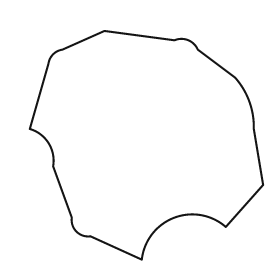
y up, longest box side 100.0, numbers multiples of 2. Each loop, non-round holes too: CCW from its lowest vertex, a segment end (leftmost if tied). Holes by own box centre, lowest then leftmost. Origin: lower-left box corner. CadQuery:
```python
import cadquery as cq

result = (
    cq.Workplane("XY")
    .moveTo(48.0, 0.0)
    .threePointArc((62.0, 18.0), (84.0, 14.0))
    .lineTo(100.0, 32.0)
    .lineTo(96.0, 56.0)
    .threePointArc((94.0, 68.0), (88.0, 78.0))
    .lineTo(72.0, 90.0)
    .threePointArc((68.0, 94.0), (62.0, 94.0))
    .lineTo(32.0, 98.0)
    .lineTo(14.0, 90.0)
    .threePointArc((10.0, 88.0), (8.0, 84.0))
    .lineTo(0.0, 56.0)
    .threePointArc((8.0, 50.0), (10.0, 40.0))
    .lineTo(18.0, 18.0)
    .threePointArc((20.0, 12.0), (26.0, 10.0))
    .close()
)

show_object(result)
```